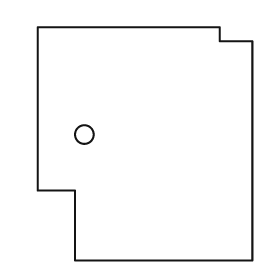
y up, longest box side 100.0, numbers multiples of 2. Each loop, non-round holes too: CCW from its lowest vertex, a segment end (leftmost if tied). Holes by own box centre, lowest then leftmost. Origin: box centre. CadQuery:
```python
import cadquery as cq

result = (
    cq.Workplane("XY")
    .moveTo(-30.0, -50.0)
    .lineTo(46.0, -50.0)
    .lineTo(46.0, 44.0)
    .lineTo(32.0, 44.0)
    .lineTo(32.0, 50.0)
    .lineTo(-46.0, 50.0)
    .lineTo(-46.0, -20.0)
    .lineTo(-30.0, -20.0)
    .close()
    .moveTo(-26.0, 4.0)
    .circle(4.0)
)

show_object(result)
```